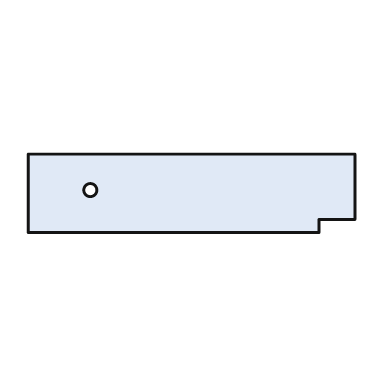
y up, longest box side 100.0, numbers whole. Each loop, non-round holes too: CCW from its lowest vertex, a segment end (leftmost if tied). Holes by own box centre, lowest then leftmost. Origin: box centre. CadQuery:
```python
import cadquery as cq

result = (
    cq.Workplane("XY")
    .moveTo(-50.0, -12.0)
    .lineTo(39.0, -12.0)
    .lineTo(39.0, -8.0)
    .lineTo(50.0, -8.0)
    .lineTo(50.0, 12.0)
    .lineTo(-50.0, 12.0)
    .close()
    .moveTo(-31.0, 1.0)
    .circle(2.0)
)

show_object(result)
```